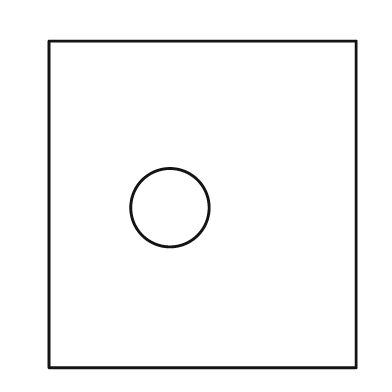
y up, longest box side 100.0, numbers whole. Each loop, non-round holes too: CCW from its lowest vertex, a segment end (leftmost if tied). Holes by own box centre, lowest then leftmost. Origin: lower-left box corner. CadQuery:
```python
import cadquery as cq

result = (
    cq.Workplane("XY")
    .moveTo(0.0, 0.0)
    .lineTo(94.0, 0.0)
    .lineTo(94.0, 100.0)
    .lineTo(0.0, 100.0)
    .close()
    .moveTo(37.0, 49.0)
    .circle(12.0)
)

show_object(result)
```